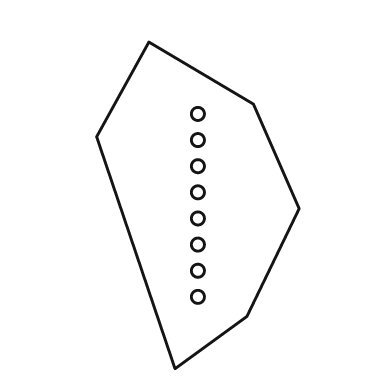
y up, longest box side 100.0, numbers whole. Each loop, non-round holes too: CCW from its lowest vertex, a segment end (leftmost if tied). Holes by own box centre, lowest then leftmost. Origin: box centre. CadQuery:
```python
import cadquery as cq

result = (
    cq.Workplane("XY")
    .moveTo(-7.0, -50.0)
    .lineTo(15.0, -34.0)
    .lineTo(31.0, -1.0)
    .lineTo(17.0, 31.0)
    .lineTo(-15.0, 50.0)
    .lineTo(-31.0, 21.0)
    .close()
    .moveTo(0.0, -28.0)
    .circle(2.0)
    .moveTo(0.0, -20.0)
    .circle(2.0)
    .moveTo(0.0, -12.0)
    .circle(2.0)
    .moveTo(0.0, -4.0)
    .circle(2.0)
    .moveTo(0.0, 4.0)
    .circle(2.0)
    .moveTo(0.0, 12.0)
    .circle(2.0)
    .moveTo(0.0, 20.0)
    .circle(2.0)
    .moveTo(0.0, 28.0)
    .circle(2.0)
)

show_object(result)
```